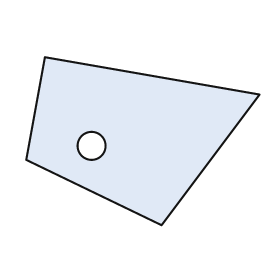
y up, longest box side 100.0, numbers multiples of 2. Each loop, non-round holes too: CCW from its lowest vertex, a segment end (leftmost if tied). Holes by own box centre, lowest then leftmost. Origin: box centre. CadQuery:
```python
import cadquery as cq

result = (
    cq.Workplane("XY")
    .moveTo(8.0, -36.0)
    .lineTo(50.0, 20.0)
    .lineTo(-42.0, 36.0)
    .lineTo(-50.0, -8.0)
    .close()
    .moveTo(-22.0, -2.0)
    .circle(6.0)
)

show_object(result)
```